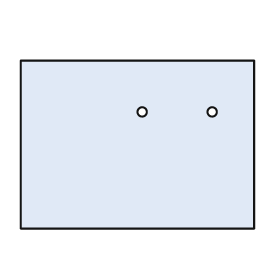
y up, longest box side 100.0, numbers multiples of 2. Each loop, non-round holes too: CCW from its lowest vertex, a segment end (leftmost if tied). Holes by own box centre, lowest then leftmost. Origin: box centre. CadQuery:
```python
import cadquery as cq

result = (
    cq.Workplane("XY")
    .moveTo(-50.0, -36.0)
    .lineTo(50.0, -36.0)
    .lineTo(50.0, 36.0)
    .lineTo(-50.0, 36.0)
    .close()
    .moveTo(2.0, 14.0)
    .circle(2.0)
    .moveTo(32.0, 14.0)
    .circle(2.0)
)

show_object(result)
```